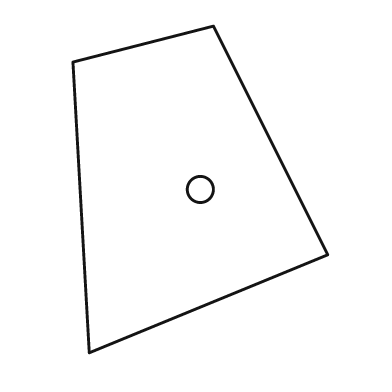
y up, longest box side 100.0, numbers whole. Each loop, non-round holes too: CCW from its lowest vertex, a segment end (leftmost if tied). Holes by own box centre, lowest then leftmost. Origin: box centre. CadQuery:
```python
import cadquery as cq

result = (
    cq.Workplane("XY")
    .moveTo(-34.0, -50.0)
    .lineTo(39.0, -20.0)
    .lineTo(4.0, 50.0)
    .lineTo(-39.0, 39.0)
    .close()
    .moveTo(0.0, 0.0)
    .circle(4.0)
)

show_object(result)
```